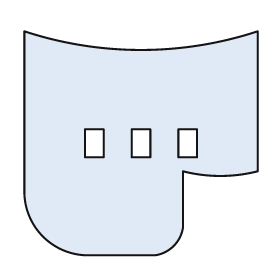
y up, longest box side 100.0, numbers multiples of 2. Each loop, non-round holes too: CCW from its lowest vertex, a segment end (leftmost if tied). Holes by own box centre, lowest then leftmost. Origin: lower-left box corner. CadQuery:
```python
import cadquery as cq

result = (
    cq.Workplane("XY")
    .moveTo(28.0, 0.0)
    .lineTo(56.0, 0.0)
    .threePointArc((64.0, 4.0), (68.0, 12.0))
    .lineTo(68.0, 36.0)
    .threePointArc((84.0, 34.0), (100.0, 36.0))
    .lineTo(100.0, 96.0)
    .threePointArc((50.0, 88.0), (0.0, 96.0))
    .lineTo(0.0, 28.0)
    .threePointArc((8.0, 8.0), (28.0, 0.0))
    .close()
    .moveTo(26.0, 42.0)
    .lineTo(34.0, 42.0)
    .lineTo(34.0, 54.0)
    .lineTo(26.0, 54.0)
    .close()
    .moveTo(46.0, 42.0)
    .lineTo(54.0, 42.0)
    .lineTo(54.0, 54.0)
    .lineTo(46.0, 54.0)
    .close()
    .moveTo(66.0, 42.0)
    .lineTo(74.0, 42.0)
    .lineTo(74.0, 54.0)
    .lineTo(66.0, 54.0)
    .close()
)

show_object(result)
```